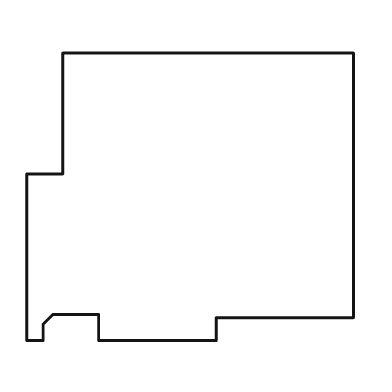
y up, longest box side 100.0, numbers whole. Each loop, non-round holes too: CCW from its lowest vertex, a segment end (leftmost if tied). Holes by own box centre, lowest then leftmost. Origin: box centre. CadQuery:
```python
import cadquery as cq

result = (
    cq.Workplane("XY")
    .moveTo(-50.0, -44.0)
    .lineTo(-45.0, -44.0)
    .lineTo(-45.0, -39.0)
    .lineTo(-42.0, -36.0)
    .lineTo(-28.0, -36.0)
    .lineTo(-28.0, -44.0)
    .lineTo(8.0, -44.0)
    .lineTo(8.0, -37.0)
    .lineTo(50.0, -37.0)
    .lineTo(50.0, 44.0)
    .lineTo(-39.0, 44.0)
    .lineTo(-39.0, 7.0)
    .lineTo(-50.0, 7.0)
    .close()
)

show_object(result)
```